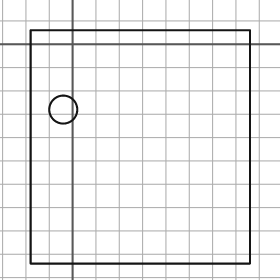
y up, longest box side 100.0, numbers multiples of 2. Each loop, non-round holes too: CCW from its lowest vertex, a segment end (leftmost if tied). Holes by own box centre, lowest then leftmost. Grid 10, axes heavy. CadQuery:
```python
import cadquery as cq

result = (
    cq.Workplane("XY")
    .moveTo(-18.0, -94.0)
    .lineTo(76.0, -94.0)
    .lineTo(76.0, 6.0)
    .lineTo(-18.0, 6.0)
    .close()
    .moveTo(-4.0, -28.0)
    .circle(6.0)
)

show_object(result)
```